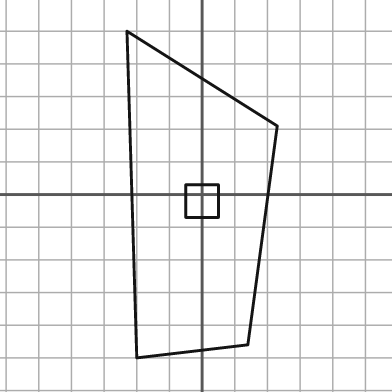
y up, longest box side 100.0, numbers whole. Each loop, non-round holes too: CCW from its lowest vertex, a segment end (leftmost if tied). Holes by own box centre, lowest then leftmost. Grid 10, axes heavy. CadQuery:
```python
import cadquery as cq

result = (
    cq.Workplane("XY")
    .moveTo(-20.0, -50.0)
    .lineTo(14.0, -46.0)
    .lineTo(23.0, 21.0)
    .lineTo(-23.0, 50.0)
    .close()
    .moveTo(-5.0, -7.0)
    .lineTo(5.0, -7.0)
    .lineTo(5.0, 3.0)
    .lineTo(-5.0, 3.0)
    .close()
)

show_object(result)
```